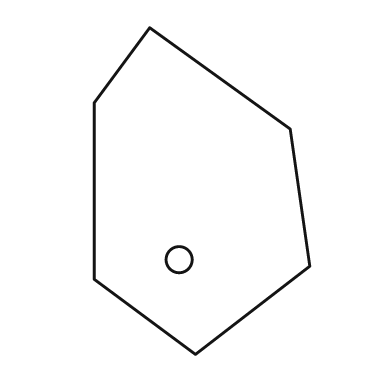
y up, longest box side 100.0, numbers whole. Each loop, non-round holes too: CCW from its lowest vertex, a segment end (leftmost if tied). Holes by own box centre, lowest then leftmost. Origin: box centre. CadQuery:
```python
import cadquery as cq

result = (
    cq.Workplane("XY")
    .moveTo(-2.0, -50.0)
    .lineTo(33.0, -23.0)
    .lineTo(27.0, 19.0)
    .lineTo(-16.0, 50.0)
    .lineTo(-33.0, 27.0)
    .lineTo(-33.0, -27.0)
    .close()
    .moveTo(-7.0, -21.0)
    .circle(4.0)
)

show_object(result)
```